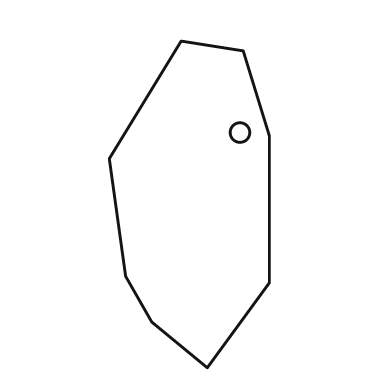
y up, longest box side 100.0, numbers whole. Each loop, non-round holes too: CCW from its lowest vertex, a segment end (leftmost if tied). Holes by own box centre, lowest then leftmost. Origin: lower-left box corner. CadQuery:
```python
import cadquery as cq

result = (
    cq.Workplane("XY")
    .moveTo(30.0, 0.0)
    .lineTo(49.0, 26.0)
    .lineTo(49.0, 71.0)
    .lineTo(41.0, 97.0)
    .lineTo(22.0, 100.0)
    .lineTo(0.0, 64.0)
    .lineTo(5.0, 28.0)
    .lineTo(13.0, 14.0)
    .close()
    .moveTo(40.0, 72.0)
    .circle(3.0)
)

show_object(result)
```